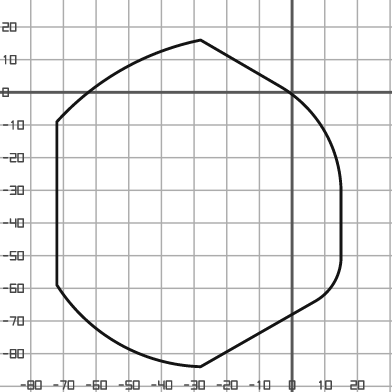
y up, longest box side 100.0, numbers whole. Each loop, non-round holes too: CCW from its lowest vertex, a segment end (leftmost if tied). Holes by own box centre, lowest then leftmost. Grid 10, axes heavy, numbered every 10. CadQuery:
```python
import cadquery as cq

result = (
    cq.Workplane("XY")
    .moveTo(-28.0, -84.0)
    .lineTo(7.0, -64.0)
    .threePointArc((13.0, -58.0), (15.0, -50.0))
    .lineTo(15.0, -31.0)
    .threePointArc((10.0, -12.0), (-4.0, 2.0))
    .lineTo(-28.0, 16.0)
    .threePointArc((-52.0, 7.0), (-72.0, -9.0))
    .lineTo(-72.0, -59.0)
    .threePointArc((-53.0, -77.0), (-28.0, -84.0))
    .close()
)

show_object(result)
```